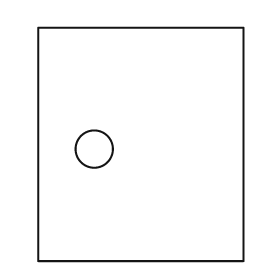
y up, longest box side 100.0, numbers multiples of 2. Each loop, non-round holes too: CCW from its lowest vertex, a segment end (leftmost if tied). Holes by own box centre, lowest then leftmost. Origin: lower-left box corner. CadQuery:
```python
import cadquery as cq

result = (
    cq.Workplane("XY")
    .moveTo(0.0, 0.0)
    .lineTo(88.0, 0.0)
    .lineTo(88.0, 100.0)
    .lineTo(0.0, 100.0)
    .close()
    .moveTo(24.0, 48.0)
    .circle(8.0)
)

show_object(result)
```